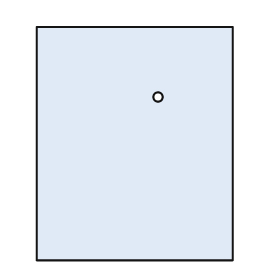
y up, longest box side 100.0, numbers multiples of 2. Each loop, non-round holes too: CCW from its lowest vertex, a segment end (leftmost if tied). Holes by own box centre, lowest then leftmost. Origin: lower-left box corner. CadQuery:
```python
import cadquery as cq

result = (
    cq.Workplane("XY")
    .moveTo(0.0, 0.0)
    .lineTo(84.0, 0.0)
    .lineTo(84.0, 100.0)
    .lineTo(0.0, 100.0)
    .close()
    .moveTo(52.0, 70.0)
    .circle(2.0)
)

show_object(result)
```